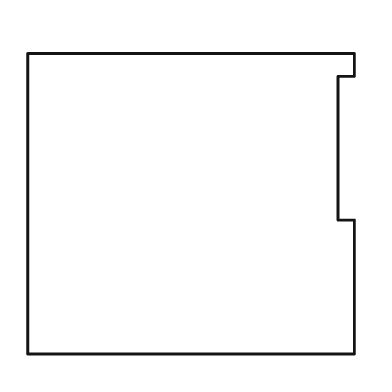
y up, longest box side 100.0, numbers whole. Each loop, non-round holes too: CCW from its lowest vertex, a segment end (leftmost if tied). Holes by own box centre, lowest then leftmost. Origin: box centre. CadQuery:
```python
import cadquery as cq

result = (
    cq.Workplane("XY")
    .moveTo(-50.0, -46.0)
    .lineTo(50.0, -46.0)
    .lineTo(50.0, -5.0)
    .lineTo(45.0, -5.0)
    .lineTo(45.0, 39.0)
    .lineTo(50.0, 39.0)
    .lineTo(50.0, 46.0)
    .lineTo(-50.0, 46.0)
    .close()
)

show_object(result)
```